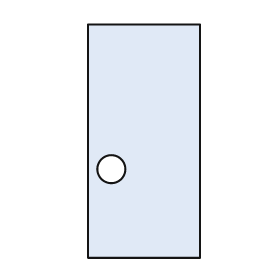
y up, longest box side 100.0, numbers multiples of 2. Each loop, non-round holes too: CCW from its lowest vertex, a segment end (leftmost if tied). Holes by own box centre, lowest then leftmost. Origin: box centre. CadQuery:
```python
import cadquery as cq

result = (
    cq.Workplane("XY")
    .moveTo(-24.0, -50.0)
    .lineTo(24.0, -50.0)
    .lineTo(24.0, 50.0)
    .lineTo(-24.0, 50.0)
    .close()
    .moveTo(-14.0, -12.0)
    .circle(6.0)
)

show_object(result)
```